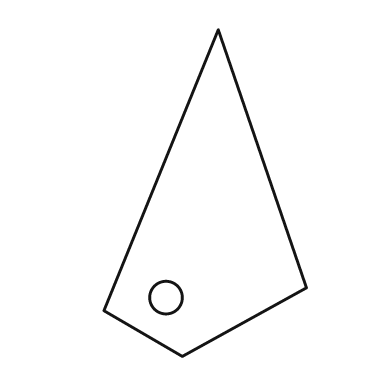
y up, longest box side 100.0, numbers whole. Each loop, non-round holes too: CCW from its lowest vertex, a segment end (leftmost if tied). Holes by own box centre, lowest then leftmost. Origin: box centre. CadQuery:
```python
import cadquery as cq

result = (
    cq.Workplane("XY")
    .moveTo(-7.0, -50.0)
    .lineTo(31.0, -29.0)
    .lineTo(4.0, 50.0)
    .lineTo(-31.0, -36.0)
    .close()
    .moveTo(-12.0, -32.0)
    .circle(5.0)
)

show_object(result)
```